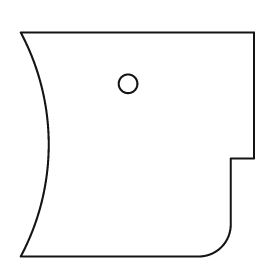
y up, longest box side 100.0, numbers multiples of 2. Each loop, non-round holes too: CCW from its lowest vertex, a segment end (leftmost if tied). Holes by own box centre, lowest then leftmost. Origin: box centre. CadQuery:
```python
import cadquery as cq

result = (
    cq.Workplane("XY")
    .moveTo(-50.0, -48.0)
    .lineTo(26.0, -48.0)
    .threePointArc((36.0, -44.0), (40.0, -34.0))
    .lineTo(40.0, -6.0)
    .lineTo(50.0, -6.0)
    .lineTo(50.0, 48.0)
    .lineTo(-50.0, 48.0)
    .threePointArc((-38.0, 0.0), (-50.0, -48.0))
    .close()
    .moveTo(-4.0, 26.0)
    .circle(4.0)
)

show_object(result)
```